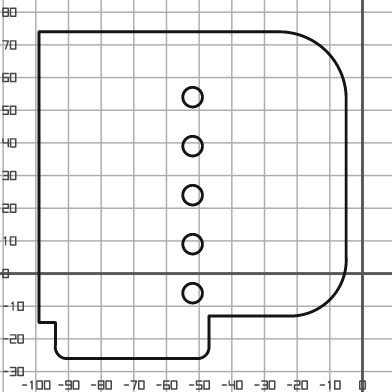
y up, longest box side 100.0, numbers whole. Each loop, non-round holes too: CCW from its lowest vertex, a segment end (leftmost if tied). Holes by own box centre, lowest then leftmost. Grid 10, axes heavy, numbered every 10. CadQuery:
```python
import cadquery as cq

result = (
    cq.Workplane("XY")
    .moveTo(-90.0, -26.0)
    .lineTo(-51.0, -26.0)
    .threePointArc((-48.0, -25.0), (-47.0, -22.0))
    .lineTo(-47.0, -13.0)
    .lineTo(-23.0, -13.0)
    .threePointArc((-10.0, -8.0), (-5.0, 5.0))
    .lineTo(-5.0, 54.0)
    .threePointArc((-11.0, 68.0), (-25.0, 74.0))
    .lineTo(-99.0, 74.0)
    .lineTo(-99.0, -15.0)
    .lineTo(-94.0, -15.0)
    .lineTo(-94.0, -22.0)
    .threePointArc((-93.0, -25.0), (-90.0, -26.0))
    .close()
    .moveTo(-52.0, -6.0)
    .circle(3.0)
    .moveTo(-52.0, 9.0)
    .circle(3.0)
    .moveTo(-52.0, 24.0)
    .circle(3.0)
    .moveTo(-52.0, 39.0)
    .circle(3.0)
    .moveTo(-52.0, 54.0)
    .circle(3.0)
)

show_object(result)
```